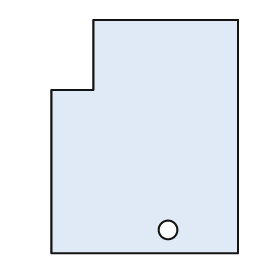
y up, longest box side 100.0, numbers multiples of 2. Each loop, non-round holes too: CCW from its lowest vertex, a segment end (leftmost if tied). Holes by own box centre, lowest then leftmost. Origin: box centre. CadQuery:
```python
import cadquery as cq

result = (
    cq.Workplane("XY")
    .moveTo(-40.0, -50.0)
    .lineTo(40.0, -50.0)
    .lineTo(40.0, 50.0)
    .lineTo(-22.0, 50.0)
    .lineTo(-22.0, 20.0)
    .lineTo(-40.0, 20.0)
    .close()
    .moveTo(10.0, -40.0)
    .circle(4.0)
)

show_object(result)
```